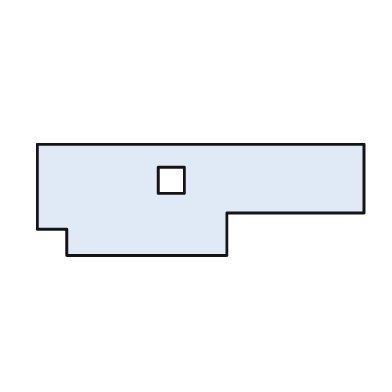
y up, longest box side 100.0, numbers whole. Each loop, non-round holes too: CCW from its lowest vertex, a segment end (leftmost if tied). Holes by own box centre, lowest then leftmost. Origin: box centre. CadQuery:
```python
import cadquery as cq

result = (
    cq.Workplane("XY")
    .moveTo(-41.0, -17.0)
    .lineTo(8.0, -17.0)
    .lineTo(8.0, -4.0)
    .lineTo(50.0, -4.0)
    .lineTo(50.0, 17.0)
    .lineTo(-50.0, 17.0)
    .lineTo(-50.0, -9.0)
    .lineTo(-41.0, -9.0)
    .close()
    .moveTo(-13.0, 2.0)
    .lineTo(-5.0, 2.0)
    .lineTo(-5.0, 10.0)
    .lineTo(-13.0, 10.0)
    .close()
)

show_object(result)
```